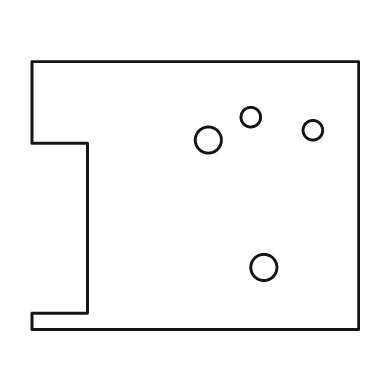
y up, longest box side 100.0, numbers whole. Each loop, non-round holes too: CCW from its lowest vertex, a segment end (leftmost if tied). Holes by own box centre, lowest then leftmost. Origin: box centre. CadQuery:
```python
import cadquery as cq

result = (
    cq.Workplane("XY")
    .moveTo(-50.0, -41.0)
    .lineTo(50.0, -41.0)
    .lineTo(50.0, 41.0)
    .lineTo(-50.0, 41.0)
    .lineTo(-50.0, 16.0)
    .lineTo(-33.0, 16.0)
    .lineTo(-33.0, -36.0)
    .lineTo(-50.0, -36.0)
    .close()
    .moveTo(21.0, -22.0)
    .circle(4.0)
    .moveTo(4.0, 17.0)
    .circle(4.0)
    .moveTo(36.0, 20.0)
    .circle(3.0)
    .moveTo(17.0, 24.0)
    .circle(3.0)
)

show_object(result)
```